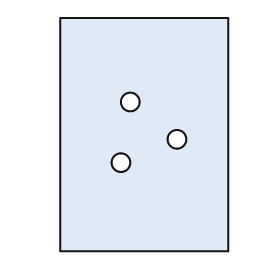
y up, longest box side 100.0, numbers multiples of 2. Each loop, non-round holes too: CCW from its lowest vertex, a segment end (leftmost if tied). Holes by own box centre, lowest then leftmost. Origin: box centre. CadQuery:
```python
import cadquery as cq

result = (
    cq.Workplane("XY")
    .moveTo(-36.0, -50.0)
    .lineTo(36.0, -50.0)
    .lineTo(36.0, 50.0)
    .lineTo(-36.0, 50.0)
    .close()
    .moveTo(-10.0, -12.0)
    .circle(4.0)
    .moveTo(14.0, -2.0)
    .circle(4.0)
    .moveTo(-6.0, 14.0)
    .circle(4.0)
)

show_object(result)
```